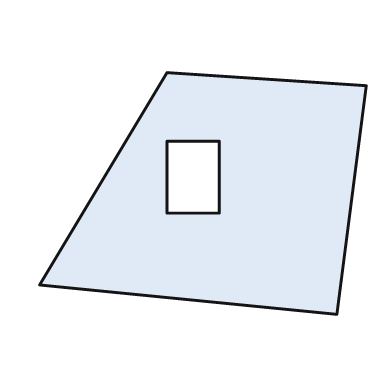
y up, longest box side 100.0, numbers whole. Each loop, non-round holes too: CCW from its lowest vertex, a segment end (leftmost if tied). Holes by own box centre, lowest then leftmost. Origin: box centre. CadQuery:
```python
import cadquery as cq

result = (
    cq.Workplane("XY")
    .moveTo(41.0, -37.0)
    .lineTo(50.0, 33.0)
    .lineTo(-11.0, 37.0)
    .lineTo(-50.0, -28.0)
    .close()
    .moveTo(-11.0, -6.0)
    .lineTo(5.0, -6.0)
    .lineTo(5.0, 16.0)
    .lineTo(-11.0, 16.0)
    .close()
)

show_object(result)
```